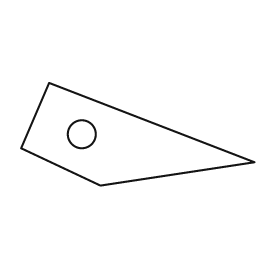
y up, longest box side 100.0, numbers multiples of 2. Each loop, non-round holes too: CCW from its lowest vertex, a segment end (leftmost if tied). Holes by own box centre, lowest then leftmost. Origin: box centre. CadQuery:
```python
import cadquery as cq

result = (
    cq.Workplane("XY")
    .moveTo(-16.0, -22.0)
    .lineTo(50.0, -12.0)
    .lineTo(-38.0, 22.0)
    .lineTo(-50.0, -6.0)
    .close()
    .moveTo(-24.0, 0.0)
    .circle(6.0)
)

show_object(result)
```